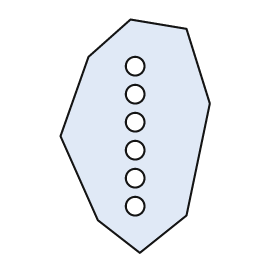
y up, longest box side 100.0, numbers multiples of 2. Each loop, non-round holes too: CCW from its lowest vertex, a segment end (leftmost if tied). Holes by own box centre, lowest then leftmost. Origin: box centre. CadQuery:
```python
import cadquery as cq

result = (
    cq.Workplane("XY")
    .moveTo(2.0, -50.0)
    .lineTo(22.0, -34.0)
    .lineTo(32.0, 14.0)
    .lineTo(22.0, 46.0)
    .lineTo(-2.0, 50.0)
    .lineTo(-20.0, 34.0)
    .lineTo(-32.0, 0.0)
    .lineTo(-16.0, -36.0)
    .close()
    .moveTo(0.0, -30.0)
    .circle(4.0)
    .moveTo(0.0, -18.0)
    .circle(4.0)
    .moveTo(0.0, -6.0)
    .circle(4.0)
    .moveTo(0.0, 6.0)
    .circle(4.0)
    .moveTo(0.0, 18.0)
    .circle(4.0)
    .moveTo(0.0, 30.0)
    .circle(4.0)
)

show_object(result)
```